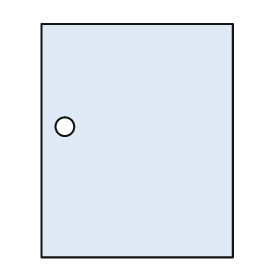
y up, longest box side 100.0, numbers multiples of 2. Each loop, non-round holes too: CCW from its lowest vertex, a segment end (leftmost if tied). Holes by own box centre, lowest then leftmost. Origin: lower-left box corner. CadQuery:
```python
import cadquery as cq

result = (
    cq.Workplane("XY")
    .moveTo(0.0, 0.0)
    .lineTo(82.0, 0.0)
    .lineTo(82.0, 100.0)
    .lineTo(0.0, 100.0)
    .close()
    .moveTo(10.0, 56.0)
    .circle(4.0)
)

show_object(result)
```